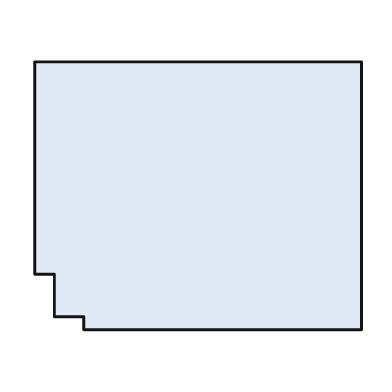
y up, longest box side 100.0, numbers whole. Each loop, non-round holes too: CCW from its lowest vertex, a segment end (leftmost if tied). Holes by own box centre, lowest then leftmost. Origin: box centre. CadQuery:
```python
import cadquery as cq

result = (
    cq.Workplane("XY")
    .moveTo(-35.0, -41.0)
    .lineTo(50.0, -41.0)
    .lineTo(50.0, 41.0)
    .lineTo(-50.0, 41.0)
    .lineTo(-50.0, -24.0)
    .lineTo(-44.0, -24.0)
    .lineTo(-44.0, -37.0)
    .lineTo(-35.0, -37.0)
    .close()
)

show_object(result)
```